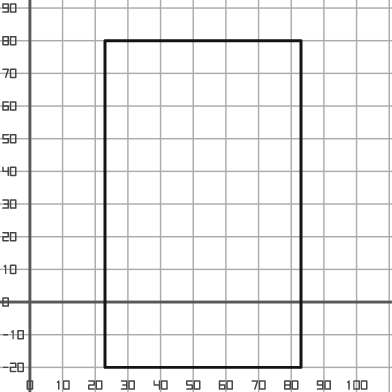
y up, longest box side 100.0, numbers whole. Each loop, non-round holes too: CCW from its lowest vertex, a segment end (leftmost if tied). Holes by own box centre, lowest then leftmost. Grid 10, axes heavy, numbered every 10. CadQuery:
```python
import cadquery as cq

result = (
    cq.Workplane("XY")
    .moveTo(23.0, -20.0)
    .lineTo(83.0, -20.0)
    .lineTo(83.0, 80.0)
    .lineTo(23.0, 80.0)
    .close()
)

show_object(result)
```